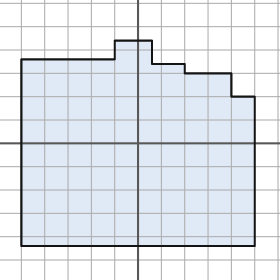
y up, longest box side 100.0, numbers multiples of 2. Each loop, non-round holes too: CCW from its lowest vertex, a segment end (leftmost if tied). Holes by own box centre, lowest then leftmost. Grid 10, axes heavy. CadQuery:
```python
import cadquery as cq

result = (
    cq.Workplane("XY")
    .moveTo(-50.0, -44.0)
    .lineTo(50.0, -44.0)
    .lineTo(50.0, 20.0)
    .lineTo(40.0, 20.0)
    .lineTo(40.0, 30.0)
    .lineTo(20.0, 30.0)
    .lineTo(20.0, 34.0)
    .lineTo(6.0, 34.0)
    .lineTo(6.0, 44.0)
    .lineTo(-10.0, 44.0)
    .lineTo(-10.0, 36.0)
    .lineTo(-50.0, 36.0)
    .close()
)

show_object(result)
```